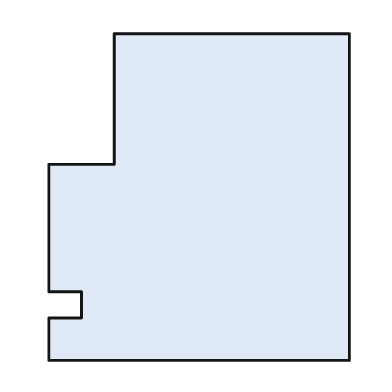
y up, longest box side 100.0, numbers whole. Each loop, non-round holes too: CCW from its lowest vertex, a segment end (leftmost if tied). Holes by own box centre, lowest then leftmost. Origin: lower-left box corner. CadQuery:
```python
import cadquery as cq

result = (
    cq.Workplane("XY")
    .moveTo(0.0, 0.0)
    .lineTo(92.0, 0.0)
    .lineTo(92.0, 100.0)
    .lineTo(20.0, 100.0)
    .lineTo(20.0, 60.0)
    .lineTo(0.0, 60.0)
    .lineTo(0.0, 21.0)
    .lineTo(10.0, 21.0)
    .lineTo(10.0, 13.0)
    .lineTo(0.0, 13.0)
    .close()
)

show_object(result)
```